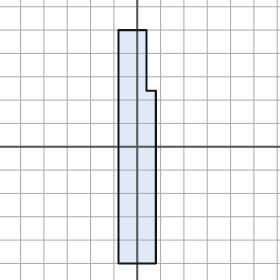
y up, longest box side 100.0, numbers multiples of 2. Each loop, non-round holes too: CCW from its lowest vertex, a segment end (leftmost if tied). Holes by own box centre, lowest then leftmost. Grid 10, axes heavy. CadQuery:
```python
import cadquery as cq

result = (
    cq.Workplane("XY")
    .moveTo(-8.0, -50.0)
    .lineTo(8.0, -50.0)
    .lineTo(8.0, 24.0)
    .lineTo(4.0, 24.0)
    .lineTo(4.0, 50.0)
    .lineTo(-8.0, 50.0)
    .close()
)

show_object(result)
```